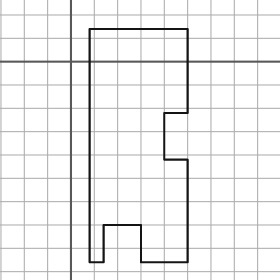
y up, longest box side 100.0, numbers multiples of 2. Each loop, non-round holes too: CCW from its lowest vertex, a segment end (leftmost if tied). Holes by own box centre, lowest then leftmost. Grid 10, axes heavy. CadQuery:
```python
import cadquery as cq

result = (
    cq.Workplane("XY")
    .moveTo(8.0, -86.0)
    .lineTo(14.0, -86.0)
    .lineTo(14.0, -70.0)
    .lineTo(30.0, -70.0)
    .lineTo(30.0, -86.0)
    .lineTo(50.0, -86.0)
    .lineTo(50.0, -42.0)
    .lineTo(40.0, -42.0)
    .lineTo(40.0, -22.0)
    .lineTo(50.0, -22.0)
    .lineTo(50.0, 14.0)
    .lineTo(8.0, 14.0)
    .close()
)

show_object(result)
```